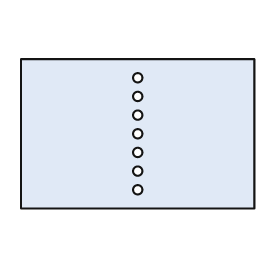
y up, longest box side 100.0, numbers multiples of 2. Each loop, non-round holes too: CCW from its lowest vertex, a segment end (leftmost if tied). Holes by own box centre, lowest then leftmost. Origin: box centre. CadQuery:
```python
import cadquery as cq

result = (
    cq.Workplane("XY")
    .moveTo(-50.0, -32.0)
    .lineTo(50.0, -32.0)
    .lineTo(50.0, 32.0)
    .lineTo(-50.0, 32.0)
    .close()
    .moveTo(0.0, -24.0)
    .circle(2.0)
    .moveTo(0.0, -16.0)
    .circle(2.0)
    .moveTo(0.0, -8.0)
    .circle(2.0)
    .moveTo(0.0, 0.0)
    .circle(2.0)
    .moveTo(0.0, 8.0)
    .circle(2.0)
    .moveTo(0.0, 16.0)
    .circle(2.0)
    .moveTo(0.0, 24.0)
    .circle(2.0)
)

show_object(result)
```